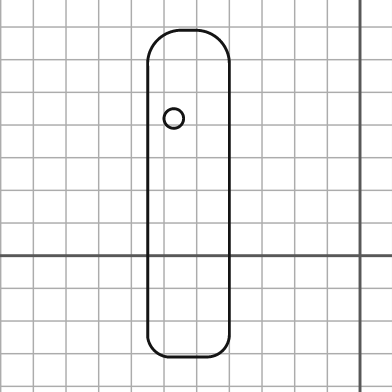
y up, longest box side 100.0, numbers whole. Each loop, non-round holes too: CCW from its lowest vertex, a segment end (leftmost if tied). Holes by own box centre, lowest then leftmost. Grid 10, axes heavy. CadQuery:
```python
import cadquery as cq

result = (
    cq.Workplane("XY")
    .moveTo(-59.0, -31.0)
    .lineTo(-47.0, -31.0)
    .threePointArc((-42.0, -29.0), (-40.0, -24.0))
    .lineTo(-40.0, 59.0)
    .threePointArc((-43.0, 66.0), (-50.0, 69.0))
    .lineTo(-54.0, 69.0)
    .threePointArc((-62.0, 66.0), (-65.0, 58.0))
    .lineTo(-65.0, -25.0)
    .threePointArc((-63.0, -29.0), (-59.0, -31.0))
    .close()
    .moveTo(-57.0, 42.0)
    .circle(3.0)
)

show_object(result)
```